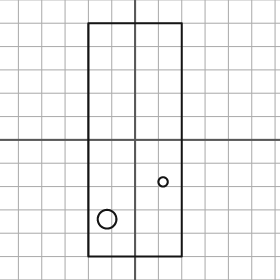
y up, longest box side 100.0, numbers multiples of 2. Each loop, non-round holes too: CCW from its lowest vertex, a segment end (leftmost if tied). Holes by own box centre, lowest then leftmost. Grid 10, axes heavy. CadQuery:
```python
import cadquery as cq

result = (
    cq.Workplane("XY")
    .moveTo(-20.0, -50.0)
    .lineTo(20.0, -50.0)
    .lineTo(20.0, 50.0)
    .lineTo(-20.0, 50.0)
    .close()
    .moveTo(-12.0, -34.0)
    .circle(4.0)
    .moveTo(12.0, -18.0)
    .circle(2.0)
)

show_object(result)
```